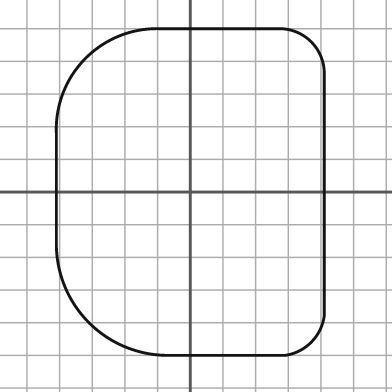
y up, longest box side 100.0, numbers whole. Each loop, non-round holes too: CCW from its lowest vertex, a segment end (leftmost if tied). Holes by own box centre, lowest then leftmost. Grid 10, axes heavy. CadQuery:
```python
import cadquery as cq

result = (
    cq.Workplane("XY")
    .moveTo(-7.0, -50.0)
    .lineTo(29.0, -50.0)
    .threePointArc((37.0, -46.0), (41.0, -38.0))
    .lineTo(41.0, 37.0)
    .threePointArc((37.0, 46.0), (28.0, 50.0))
    .lineTo(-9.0, 50.0)
    .threePointArc((-32.0, 41.0), (-41.0, 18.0))
    .lineTo(-41.0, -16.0)
    .threePointArc((-31.0, -40.0), (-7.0, -50.0))
    .close()
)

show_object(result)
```